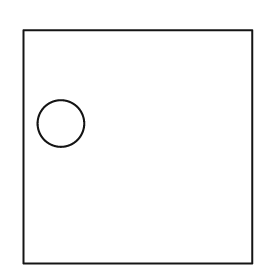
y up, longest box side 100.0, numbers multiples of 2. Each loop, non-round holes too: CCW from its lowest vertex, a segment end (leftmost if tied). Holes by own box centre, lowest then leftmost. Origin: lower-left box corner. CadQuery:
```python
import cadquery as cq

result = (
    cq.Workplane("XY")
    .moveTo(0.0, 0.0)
    .lineTo(98.0, 0.0)
    .lineTo(98.0, 100.0)
    .lineTo(0.0, 100.0)
    .close()
    .moveTo(16.0, 60.0)
    .circle(10.0)
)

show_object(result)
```